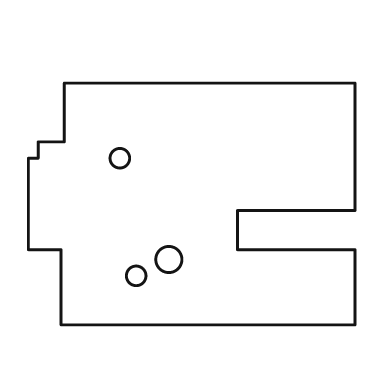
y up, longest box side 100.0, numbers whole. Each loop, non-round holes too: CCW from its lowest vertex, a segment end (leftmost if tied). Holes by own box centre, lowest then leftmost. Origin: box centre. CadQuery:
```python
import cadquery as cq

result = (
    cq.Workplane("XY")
    .moveTo(-40.0, -37.0)
    .lineTo(50.0, -37.0)
    .lineTo(50.0, -14.0)
    .lineTo(14.0, -14.0)
    .lineTo(14.0, -2.0)
    .lineTo(50.0, -2.0)
    .lineTo(50.0, 37.0)
    .lineTo(-39.0, 37.0)
    .lineTo(-39.0, 19.0)
    .lineTo(-47.0, 19.0)
    .lineTo(-47.0, 14.0)
    .lineTo(-50.0, 14.0)
    .lineTo(-50.0, -14.0)
    .lineTo(-40.0, -14.0)
    .close()
    .moveTo(-17.0, -22.0)
    .circle(3.0)
    .moveTo(-7.0, -17.0)
    .circle(4.0)
    .moveTo(-22.0, 14.0)
    .circle(3.0)
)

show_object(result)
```